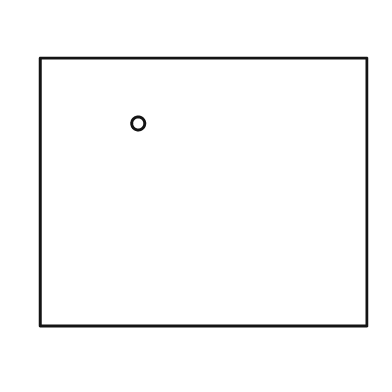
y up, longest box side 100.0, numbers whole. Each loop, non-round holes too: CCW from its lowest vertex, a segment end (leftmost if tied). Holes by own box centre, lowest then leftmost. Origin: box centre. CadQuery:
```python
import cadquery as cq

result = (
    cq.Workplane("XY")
    .moveTo(-50.0, -41.0)
    .lineTo(50.0, -41.0)
    .lineTo(50.0, 41.0)
    .lineTo(-50.0, 41.0)
    .close()
    .moveTo(-20.0, 21.0)
    .circle(2.0)
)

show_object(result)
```